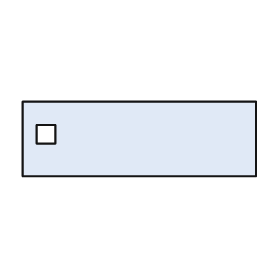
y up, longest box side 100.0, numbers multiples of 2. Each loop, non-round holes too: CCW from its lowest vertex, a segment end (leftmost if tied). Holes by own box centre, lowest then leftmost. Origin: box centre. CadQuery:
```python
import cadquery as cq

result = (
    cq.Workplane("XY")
    .moveTo(-50.0, -16.0)
    .lineTo(50.0, -16.0)
    .lineTo(50.0, 16.0)
    .lineTo(-50.0, 16.0)
    .close()
    .moveTo(-44.0, -2.0)
    .lineTo(-36.0, -2.0)
    .lineTo(-36.0, 6.0)
    .lineTo(-44.0, 6.0)
    .close()
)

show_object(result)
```